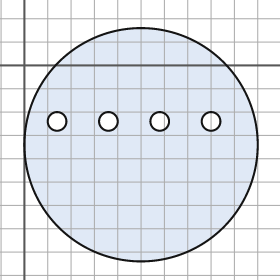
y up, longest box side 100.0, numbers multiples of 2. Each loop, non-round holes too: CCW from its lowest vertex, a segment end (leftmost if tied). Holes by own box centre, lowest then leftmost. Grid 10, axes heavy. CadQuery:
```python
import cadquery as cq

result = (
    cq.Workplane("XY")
    .moveTo(50.0, -34.0)
    .circle(50.0)
    .moveTo(14.0, -24.0)
    .circle(4.0)
    .moveTo(36.0, -24.0)
    .circle(4.0)
    .moveTo(58.0, -24.0)
    .circle(4.0)
    .moveTo(80.0, -24.0)
    .circle(4.0)
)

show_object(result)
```